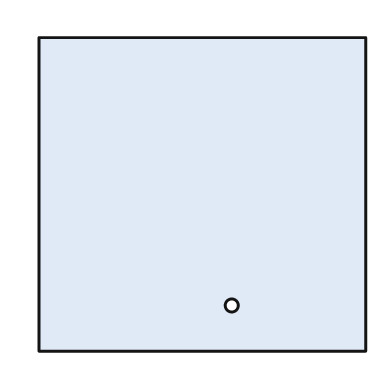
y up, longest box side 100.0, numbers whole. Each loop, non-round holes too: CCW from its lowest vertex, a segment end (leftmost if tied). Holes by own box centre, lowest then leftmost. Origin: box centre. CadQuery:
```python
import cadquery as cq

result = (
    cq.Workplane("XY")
    .moveTo(-50.0, -48.0)
    .lineTo(50.0, -48.0)
    .lineTo(50.0, 48.0)
    .lineTo(-50.0, 48.0)
    .close()
    .moveTo(9.0, -34.0)
    .circle(2.0)
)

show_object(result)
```